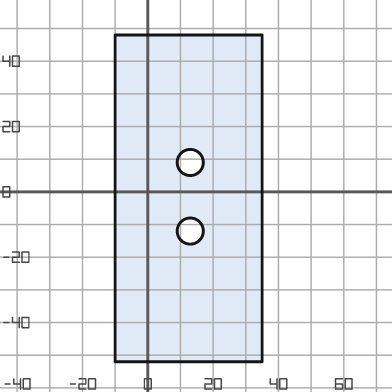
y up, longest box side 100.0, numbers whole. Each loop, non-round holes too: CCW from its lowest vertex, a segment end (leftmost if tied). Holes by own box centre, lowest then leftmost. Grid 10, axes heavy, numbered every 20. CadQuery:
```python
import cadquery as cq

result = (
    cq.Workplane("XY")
    .moveTo(-10.0, -52.0)
    .lineTo(35.0, -52.0)
    .lineTo(35.0, 48.0)
    .lineTo(-10.0, 48.0)
    .close()
    .moveTo(13.0, -12.0)
    .circle(4.0)
    .moveTo(13.0, 9.0)
    .circle(4.0)
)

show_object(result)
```